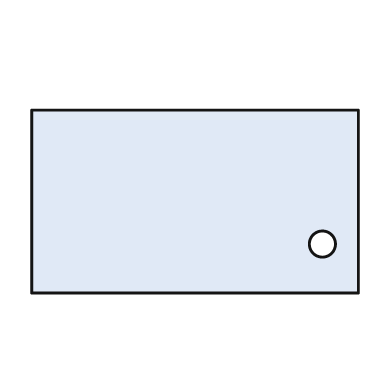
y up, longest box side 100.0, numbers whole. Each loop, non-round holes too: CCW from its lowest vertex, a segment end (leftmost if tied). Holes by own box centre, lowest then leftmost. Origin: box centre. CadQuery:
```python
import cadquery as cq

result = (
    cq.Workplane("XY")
    .moveTo(-50.0, -28.0)
    .lineTo(50.0, -28.0)
    .lineTo(50.0, 28.0)
    .lineTo(-50.0, 28.0)
    .close()
    .moveTo(39.0, -13.0)
    .circle(4.0)
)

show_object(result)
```